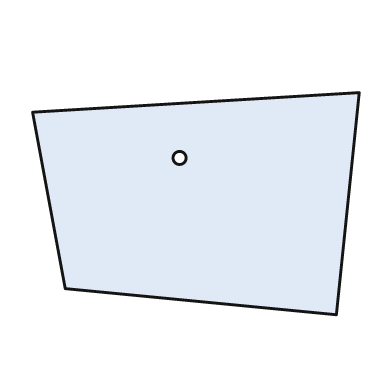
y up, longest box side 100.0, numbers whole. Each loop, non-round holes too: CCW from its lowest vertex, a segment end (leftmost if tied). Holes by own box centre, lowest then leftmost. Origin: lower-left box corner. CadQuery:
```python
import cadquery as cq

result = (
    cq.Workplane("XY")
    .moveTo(93.0, 0.0)
    .lineTo(100.0, 68.0)
    .lineTo(0.0, 62.0)
    .lineTo(10.0, 8.0)
    .close()
    .moveTo(45.0, 48.0)
    .circle(2.0)
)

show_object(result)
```